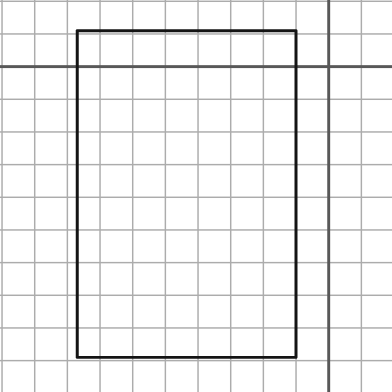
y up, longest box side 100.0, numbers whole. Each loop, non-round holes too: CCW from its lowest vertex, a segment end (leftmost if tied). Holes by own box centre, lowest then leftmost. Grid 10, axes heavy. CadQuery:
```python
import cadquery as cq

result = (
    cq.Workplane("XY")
    .moveTo(-77.0, -89.0)
    .lineTo(-10.0, -89.0)
    .lineTo(-10.0, 11.0)
    .lineTo(-77.0, 11.0)
    .close()
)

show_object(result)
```